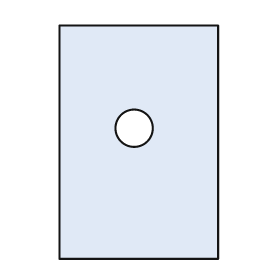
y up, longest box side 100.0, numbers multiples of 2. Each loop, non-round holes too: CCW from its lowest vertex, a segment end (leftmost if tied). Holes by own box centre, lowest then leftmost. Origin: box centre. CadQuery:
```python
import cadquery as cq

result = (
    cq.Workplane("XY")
    .moveTo(-34.0, -50.0)
    .lineTo(34.0, -50.0)
    .lineTo(34.0, 50.0)
    .lineTo(-34.0, 50.0)
    .close()
    .moveTo(-2.0, 6.0)
    .circle(8.0)
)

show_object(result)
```